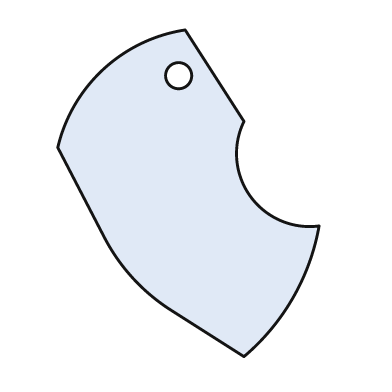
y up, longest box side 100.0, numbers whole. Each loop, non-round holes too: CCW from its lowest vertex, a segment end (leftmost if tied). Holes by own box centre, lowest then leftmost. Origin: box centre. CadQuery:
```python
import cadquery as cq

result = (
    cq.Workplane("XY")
    .moveTo(17.0, -50.0)
    .threePointArc((32.0, -32.0), (40.0, -10.0))
    .threePointArc((19.0, -1.0), (17.0, 22.0))
    .lineTo(-1.0, 50.0)
    .threePointArc((-26.0, 38.0), (-40.0, 14.0))
    .lineTo(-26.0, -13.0)
    .threePointArc((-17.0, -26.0), (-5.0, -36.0))
    .close()
    .moveTo(-3.0, 36.0)
    .circle(4.0)
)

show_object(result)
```